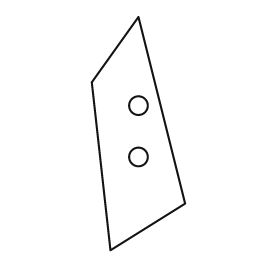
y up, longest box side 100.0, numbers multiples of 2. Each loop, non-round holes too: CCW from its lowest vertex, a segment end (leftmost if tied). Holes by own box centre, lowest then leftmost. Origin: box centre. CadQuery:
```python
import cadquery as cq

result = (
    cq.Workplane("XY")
    .moveTo(-12.0, -50.0)
    .lineTo(20.0, -30.0)
    .lineTo(0.0, 50.0)
    .lineTo(-20.0, 22.0)
    .close()
    .moveTo(0.0, -10.0)
    .circle(4.0)
    .moveTo(0.0, 12.0)
    .circle(4.0)
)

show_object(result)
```